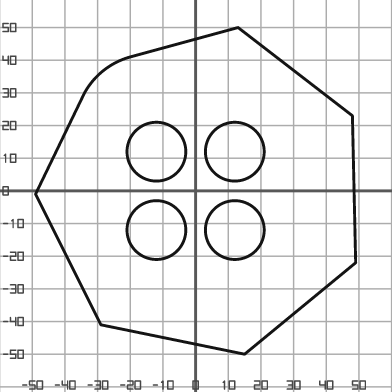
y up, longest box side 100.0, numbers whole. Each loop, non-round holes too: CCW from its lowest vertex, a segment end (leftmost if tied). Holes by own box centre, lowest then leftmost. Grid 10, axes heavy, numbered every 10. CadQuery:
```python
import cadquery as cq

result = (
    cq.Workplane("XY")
    .moveTo(15.0, -50.0)
    .lineTo(49.0, -22.0)
    .lineTo(48.0, 23.0)
    .lineTo(13.0, 50.0)
    .lineTo(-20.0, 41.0)
    .threePointArc((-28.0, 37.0), (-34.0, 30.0))
    .lineTo(-49.0, -1.0)
    .lineTo(-29.0, -41.0)
    .close()
    .moveTo(-12.0, -12.0)
    .circle(9.0)
    .moveTo(12.0, -12.0)
    .circle(9.0)
    .moveTo(-12.0, 12.0)
    .circle(9.0)
    .moveTo(12.0, 12.0)
    .circle(9.0)
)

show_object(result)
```